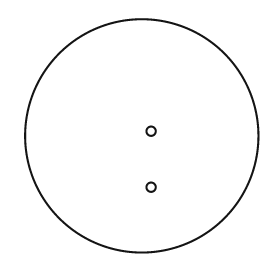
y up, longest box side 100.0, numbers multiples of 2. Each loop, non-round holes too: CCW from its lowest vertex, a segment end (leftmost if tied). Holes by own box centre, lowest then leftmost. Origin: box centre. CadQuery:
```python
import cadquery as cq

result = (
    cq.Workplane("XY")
    .moveTo(0.0, 0.0)
    .circle(50.0)
    .moveTo(4.0, -22.0)
    .circle(2.0)
    .moveTo(4.0, 2.0)
    .circle(2.0)
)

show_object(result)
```